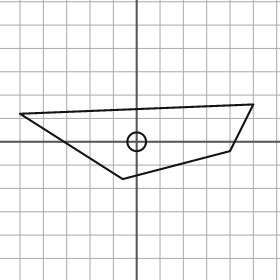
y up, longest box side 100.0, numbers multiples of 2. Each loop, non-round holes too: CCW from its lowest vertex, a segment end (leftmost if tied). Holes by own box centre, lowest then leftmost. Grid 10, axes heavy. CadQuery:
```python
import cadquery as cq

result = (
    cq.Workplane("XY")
    .moveTo(-6.0, -16.0)
    .lineTo(40.0, -4.0)
    .lineTo(50.0, 16.0)
    .lineTo(-50.0, 12.0)
    .close()
    .moveTo(0.0, 0.0)
    .circle(4.0)
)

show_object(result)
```